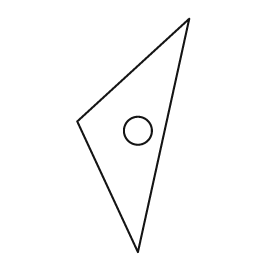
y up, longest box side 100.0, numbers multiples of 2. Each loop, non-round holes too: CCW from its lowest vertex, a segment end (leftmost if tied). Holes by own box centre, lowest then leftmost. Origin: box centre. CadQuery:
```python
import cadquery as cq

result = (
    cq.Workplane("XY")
    .moveTo(2.0, -50.0)
    .lineTo(24.0, 50.0)
    .lineTo(-24.0, 6.0)
    .close()
    .moveTo(2.0, 2.0)
    .circle(6.0)
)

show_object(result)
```